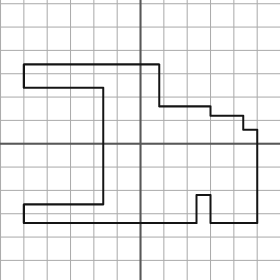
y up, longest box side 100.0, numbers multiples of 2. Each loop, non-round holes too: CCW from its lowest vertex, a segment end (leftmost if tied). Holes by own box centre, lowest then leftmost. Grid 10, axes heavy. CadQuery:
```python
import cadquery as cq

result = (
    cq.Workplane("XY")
    .moveTo(-50.0, -34.0)
    .lineTo(24.0, -34.0)
    .lineTo(24.0, -22.0)
    .lineTo(30.0, -22.0)
    .lineTo(30.0, -34.0)
    .lineTo(50.0, -34.0)
    .lineTo(50.0, 6.0)
    .lineTo(44.0, 6.0)
    .lineTo(44.0, 12.0)
    .lineTo(30.0, 12.0)
    .lineTo(30.0, 16.0)
    .lineTo(8.0, 16.0)
    .lineTo(8.0, 34.0)
    .lineTo(-50.0, 34.0)
    .lineTo(-50.0, 24.0)
    .lineTo(-16.0, 24.0)
    .lineTo(-16.0, -26.0)
    .lineTo(-50.0, -26.0)
    .close()
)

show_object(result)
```